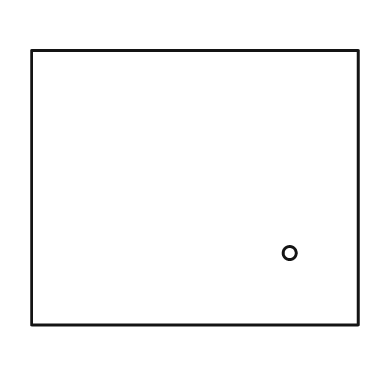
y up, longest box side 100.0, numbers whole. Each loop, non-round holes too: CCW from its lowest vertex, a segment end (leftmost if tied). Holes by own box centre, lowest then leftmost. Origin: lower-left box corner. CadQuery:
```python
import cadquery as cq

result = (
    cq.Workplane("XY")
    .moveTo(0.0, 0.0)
    .lineTo(100.0, 0.0)
    .lineTo(100.0, 84.0)
    .lineTo(0.0, 84.0)
    .close()
    .moveTo(79.0, 22.0)
    .circle(2.0)
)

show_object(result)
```